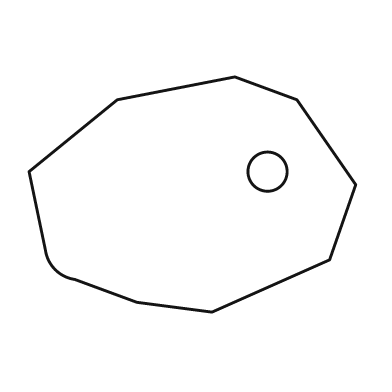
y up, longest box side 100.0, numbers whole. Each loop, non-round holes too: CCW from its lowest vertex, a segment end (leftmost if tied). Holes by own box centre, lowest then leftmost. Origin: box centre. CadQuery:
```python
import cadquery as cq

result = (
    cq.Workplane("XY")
    .moveTo(6.0, -36.0)
    .lineTo(42.0, -20.0)
    .lineTo(50.0, 3.0)
    .lineTo(32.0, 29.0)
    .lineTo(13.0, 36.0)
    .lineTo(-23.0, 29.0)
    .lineTo(-50.0, 7.0)
    .lineTo(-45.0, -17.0)
    .threePointArc((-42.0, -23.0), (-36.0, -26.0))
    .lineTo(-17.0, -33.0)
    .close()
    .moveTo(23.0, 7.0)
    .circle(6.0)
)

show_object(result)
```